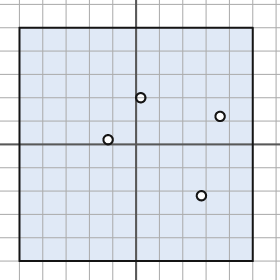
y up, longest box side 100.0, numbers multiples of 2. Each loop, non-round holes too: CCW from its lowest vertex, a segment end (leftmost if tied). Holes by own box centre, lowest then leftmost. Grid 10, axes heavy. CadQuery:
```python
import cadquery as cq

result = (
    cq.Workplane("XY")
    .moveTo(-50.0, -50.0)
    .lineTo(50.0, -50.0)
    .lineTo(50.0, 50.0)
    .lineTo(-50.0, 50.0)
    .close()
    .moveTo(28.0, -22.0)
    .circle(2.0)
    .moveTo(-12.0, 2.0)
    .circle(2.0)
    .moveTo(36.0, 12.0)
    .circle(2.0)
    .moveTo(2.0, 20.0)
    .circle(2.0)
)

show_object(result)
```